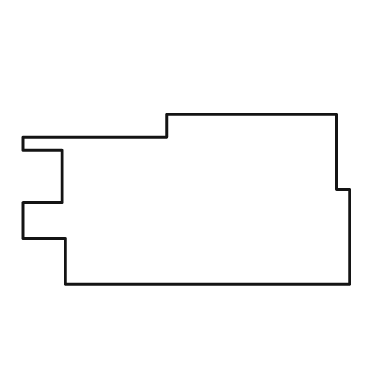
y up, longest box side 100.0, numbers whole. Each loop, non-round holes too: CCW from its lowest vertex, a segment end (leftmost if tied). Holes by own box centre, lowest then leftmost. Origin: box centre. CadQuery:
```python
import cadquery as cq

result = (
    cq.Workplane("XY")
    .moveTo(-37.0, -26.0)
    .lineTo(50.0, -26.0)
    .lineTo(50.0, 3.0)
    .lineTo(46.0, 3.0)
    .lineTo(46.0, 26.0)
    .lineTo(-6.0, 26.0)
    .lineTo(-6.0, 19.0)
    .lineTo(-50.0, 19.0)
    .lineTo(-50.0, 15.0)
    .lineTo(-38.0, 15.0)
    .lineTo(-38.0, -1.0)
    .lineTo(-50.0, -1.0)
    .lineTo(-50.0, -12.0)
    .lineTo(-37.0, -12.0)
    .close()
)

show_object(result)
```